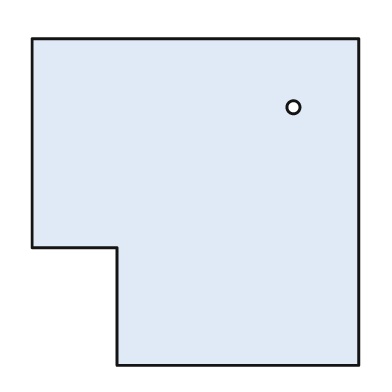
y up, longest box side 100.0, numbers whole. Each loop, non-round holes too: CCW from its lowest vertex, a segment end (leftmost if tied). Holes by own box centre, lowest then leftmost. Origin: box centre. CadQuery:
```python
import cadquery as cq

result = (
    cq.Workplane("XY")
    .moveTo(-24.0, -50.0)
    .lineTo(50.0, -50.0)
    .lineTo(50.0, 50.0)
    .lineTo(-50.0, 50.0)
    .lineTo(-50.0, -14.0)
    .lineTo(-24.0, -14.0)
    .close()
    .moveTo(30.0, 29.0)
    .circle(2.0)
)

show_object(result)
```